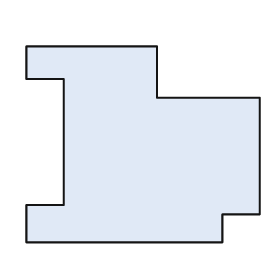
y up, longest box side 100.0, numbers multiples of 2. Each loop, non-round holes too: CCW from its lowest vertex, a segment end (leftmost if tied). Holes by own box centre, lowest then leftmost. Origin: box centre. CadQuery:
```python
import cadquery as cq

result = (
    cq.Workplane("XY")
    .moveTo(-50.0, -42.0)
    .lineTo(34.0, -42.0)
    .lineTo(34.0, -30.0)
    .lineTo(50.0, -30.0)
    .lineTo(50.0, 20.0)
    .lineTo(6.0, 20.0)
    .lineTo(6.0, 42.0)
    .lineTo(-50.0, 42.0)
    .lineTo(-50.0, 28.0)
    .lineTo(-34.0, 28.0)
    .lineTo(-34.0, -26.0)
    .lineTo(-50.0, -26.0)
    .close()
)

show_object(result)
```